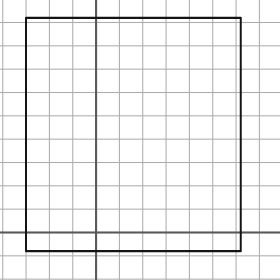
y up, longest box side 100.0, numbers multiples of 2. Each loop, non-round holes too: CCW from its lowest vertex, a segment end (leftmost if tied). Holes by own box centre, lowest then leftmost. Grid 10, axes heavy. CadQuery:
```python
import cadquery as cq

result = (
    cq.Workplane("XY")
    .moveTo(-30.0, -8.0)
    .lineTo(62.0, -8.0)
    .lineTo(62.0, 92.0)
    .lineTo(-30.0, 92.0)
    .close()
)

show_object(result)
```